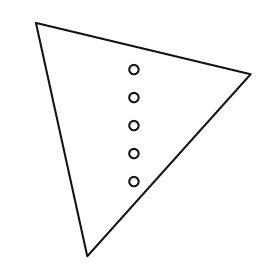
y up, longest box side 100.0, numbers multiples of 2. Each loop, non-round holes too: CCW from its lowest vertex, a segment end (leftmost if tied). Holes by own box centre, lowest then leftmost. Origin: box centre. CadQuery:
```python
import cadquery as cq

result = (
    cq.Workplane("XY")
    .moveTo(-24.0, -50.0)
    .lineTo(46.0, 28.0)
    .lineTo(-46.0, 50.0)
    .close()
    .moveTo(-4.0, -18.0)
    .circle(2.0)
    .moveTo(-4.0, -6.0)
    .circle(2.0)
    .moveTo(-4.0, 6.0)
    .circle(2.0)
    .moveTo(-4.0, 18.0)
    .circle(2.0)
    .moveTo(-4.0, 30.0)
    .circle(2.0)
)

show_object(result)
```